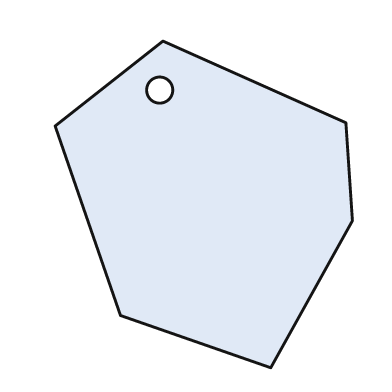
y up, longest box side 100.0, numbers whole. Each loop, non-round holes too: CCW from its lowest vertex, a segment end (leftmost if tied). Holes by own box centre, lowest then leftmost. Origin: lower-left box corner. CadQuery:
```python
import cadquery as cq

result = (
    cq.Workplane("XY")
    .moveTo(66.0, 0.0)
    .lineTo(91.0, 45.0)
    .lineTo(89.0, 75.0)
    .lineTo(33.0, 100.0)
    .lineTo(0.0, 74.0)
    .lineTo(20.0, 16.0)
    .close()
    .moveTo(32.0, 85.0)
    .circle(4.0)
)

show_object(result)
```